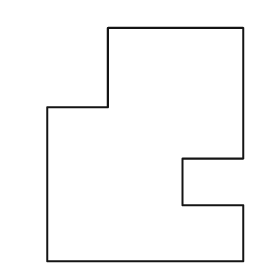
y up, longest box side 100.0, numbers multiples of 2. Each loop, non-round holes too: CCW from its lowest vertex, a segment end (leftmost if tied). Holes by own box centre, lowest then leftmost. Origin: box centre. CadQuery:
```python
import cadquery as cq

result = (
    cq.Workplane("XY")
    .moveTo(-42.0, -50.0)
    .lineTo(42.0, -50.0)
    .lineTo(42.0, -26.0)
    .lineTo(16.0, -26.0)
    .lineTo(16.0, -6.0)
    .lineTo(42.0, -6.0)
    .lineTo(42.0, 50.0)
    .lineTo(-16.0, 50.0)
    .lineTo(-16.0, 16.0)
    .lineTo(-42.0, 16.0)
    .close()
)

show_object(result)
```